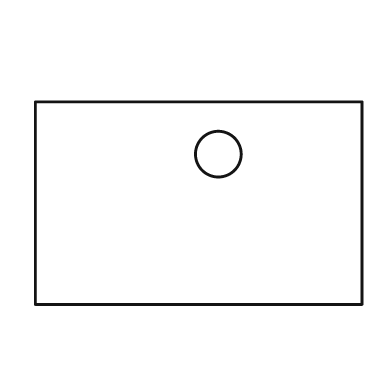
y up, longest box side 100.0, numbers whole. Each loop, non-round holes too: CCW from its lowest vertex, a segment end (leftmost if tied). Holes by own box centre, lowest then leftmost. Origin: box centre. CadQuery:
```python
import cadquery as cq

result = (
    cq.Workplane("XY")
    .moveTo(-50.0, -31.0)
    .lineTo(50.0, -31.0)
    .lineTo(50.0, 31.0)
    .lineTo(-50.0, 31.0)
    .close()
    .moveTo(6.0, 15.0)
    .circle(7.0)
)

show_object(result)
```